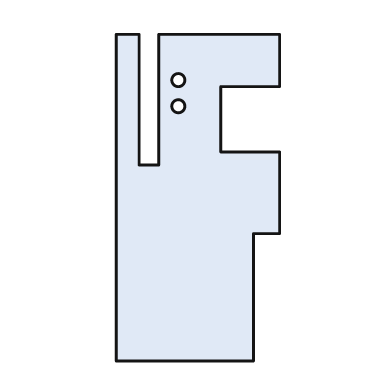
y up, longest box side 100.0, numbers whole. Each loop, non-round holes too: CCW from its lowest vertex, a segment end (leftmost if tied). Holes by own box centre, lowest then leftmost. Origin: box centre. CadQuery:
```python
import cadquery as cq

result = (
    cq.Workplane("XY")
    .moveTo(-25.0, -50.0)
    .lineTo(17.0, -50.0)
    .lineTo(17.0, -11.0)
    .lineTo(25.0, -11.0)
    .lineTo(25.0, 14.0)
    .lineTo(7.0, 14.0)
    .lineTo(7.0, 34.0)
    .lineTo(25.0, 34.0)
    .lineTo(25.0, 50.0)
    .lineTo(-12.0, 50.0)
    .lineTo(-12.0, 10.0)
    .lineTo(-18.0, 10.0)
    .lineTo(-18.0, 50.0)
    .lineTo(-25.0, 50.0)
    .close()
    .moveTo(-6.0, 28.0)
    .circle(2.0)
    .moveTo(-6.0, 36.0)
    .circle(2.0)
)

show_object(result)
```